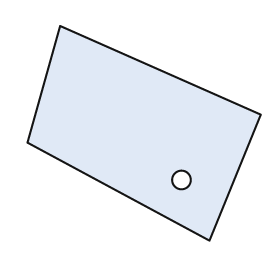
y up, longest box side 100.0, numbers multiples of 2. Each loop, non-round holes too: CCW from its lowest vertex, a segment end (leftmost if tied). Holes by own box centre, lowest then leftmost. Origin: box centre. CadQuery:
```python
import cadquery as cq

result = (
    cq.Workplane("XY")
    .moveTo(28.0, -46.0)
    .lineTo(50.0, 8.0)
    .lineTo(-36.0, 46.0)
    .lineTo(-50.0, -4.0)
    .close()
    .moveTo(16.0, -20.0)
    .circle(4.0)
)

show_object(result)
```